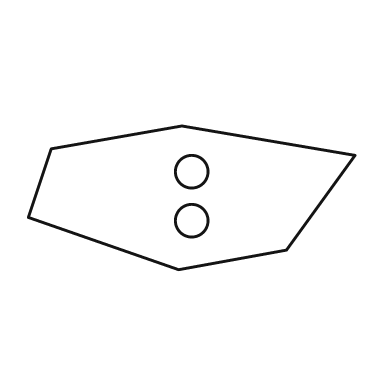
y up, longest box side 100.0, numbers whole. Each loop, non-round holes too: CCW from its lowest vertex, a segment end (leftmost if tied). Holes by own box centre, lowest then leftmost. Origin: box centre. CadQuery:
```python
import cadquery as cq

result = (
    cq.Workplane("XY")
    .moveTo(-4.0, -22.0)
    .lineTo(29.0, -16.0)
    .lineTo(50.0, 13.0)
    .lineTo(-3.0, 22.0)
    .lineTo(-43.0, 15.0)
    .lineTo(-50.0, -6.0)
    .close()
    .moveTo(0.0, -7.0)
    .circle(5.0)
    .moveTo(0.0, 8.0)
    .circle(5.0)
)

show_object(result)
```